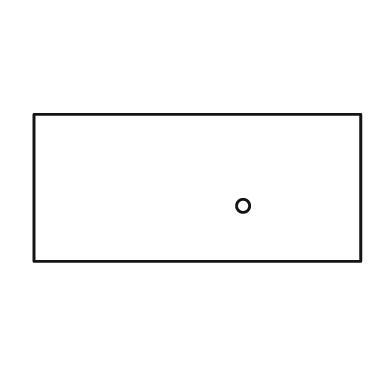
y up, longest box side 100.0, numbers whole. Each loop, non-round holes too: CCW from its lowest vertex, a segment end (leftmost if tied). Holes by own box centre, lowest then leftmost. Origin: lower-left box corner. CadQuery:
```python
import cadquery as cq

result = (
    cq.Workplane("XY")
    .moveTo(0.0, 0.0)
    .lineTo(100.0, 0.0)
    .lineTo(100.0, 45.0)
    .lineTo(0.0, 45.0)
    .close()
    .moveTo(64.0, 17.0)
    .circle(2.0)
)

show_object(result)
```